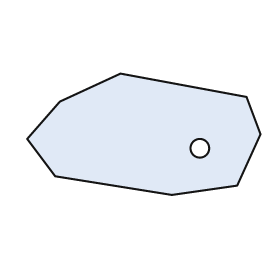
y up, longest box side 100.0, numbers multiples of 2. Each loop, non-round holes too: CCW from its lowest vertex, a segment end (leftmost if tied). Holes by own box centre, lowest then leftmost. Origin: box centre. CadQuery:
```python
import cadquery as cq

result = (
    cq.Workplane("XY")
    .moveTo(12.0, -26.0)
    .lineTo(40.0, -22.0)
    .lineTo(50.0, 0.0)
    .lineTo(44.0, 16.0)
    .lineTo(-10.0, 26.0)
    .lineTo(-36.0, 14.0)
    .lineTo(-50.0, -2.0)
    .lineTo(-38.0, -18.0)
    .close()
    .moveTo(24.0, -6.0)
    .circle(4.0)
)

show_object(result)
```